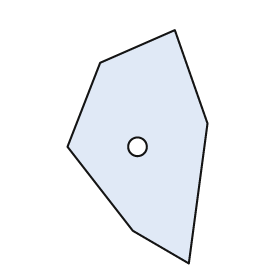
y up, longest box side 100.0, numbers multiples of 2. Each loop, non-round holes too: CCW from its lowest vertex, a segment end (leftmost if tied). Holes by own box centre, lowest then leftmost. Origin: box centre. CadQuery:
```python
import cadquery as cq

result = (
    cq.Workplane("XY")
    .moveTo(22.0, -50.0)
    .lineTo(30.0, 10.0)
    .lineTo(16.0, 50.0)
    .lineTo(-16.0, 36.0)
    .lineTo(-30.0, 0.0)
    .lineTo(-2.0, -36.0)
    .close()
    .moveTo(0.0, 0.0)
    .circle(4.0)
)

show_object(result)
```